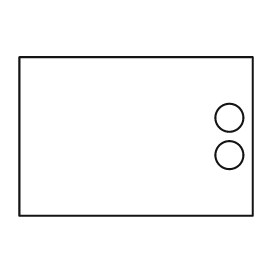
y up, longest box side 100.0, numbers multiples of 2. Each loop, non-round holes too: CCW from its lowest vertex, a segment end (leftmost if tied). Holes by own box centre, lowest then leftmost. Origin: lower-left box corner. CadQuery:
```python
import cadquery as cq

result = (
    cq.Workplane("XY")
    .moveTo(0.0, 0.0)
    .lineTo(100.0, 0.0)
    .lineTo(100.0, 68.0)
    .lineTo(0.0, 68.0)
    .close()
    .moveTo(90.0, 26.0)
    .circle(6.0)
    .moveTo(90.0, 42.0)
    .circle(6.0)
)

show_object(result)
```